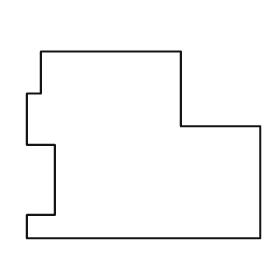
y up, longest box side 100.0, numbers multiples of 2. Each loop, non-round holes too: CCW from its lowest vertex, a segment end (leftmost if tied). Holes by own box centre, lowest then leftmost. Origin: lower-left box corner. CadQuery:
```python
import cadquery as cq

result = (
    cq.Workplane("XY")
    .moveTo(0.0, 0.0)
    .lineTo(100.0, 0.0)
    .lineTo(100.0, 48.0)
    .lineTo(66.0, 48.0)
    .lineTo(66.0, 80.0)
    .lineTo(6.0, 80.0)
    .lineTo(6.0, 62.0)
    .lineTo(0.0, 62.0)
    .lineTo(0.0, 40.0)
    .lineTo(12.0, 40.0)
    .lineTo(12.0, 10.0)
    .lineTo(0.0, 10.0)
    .close()
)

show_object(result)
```